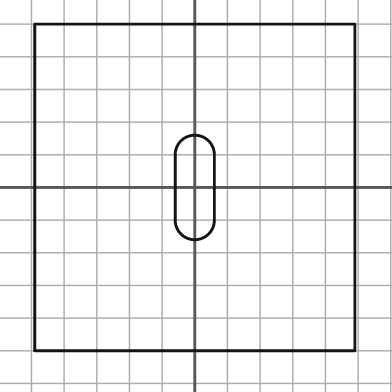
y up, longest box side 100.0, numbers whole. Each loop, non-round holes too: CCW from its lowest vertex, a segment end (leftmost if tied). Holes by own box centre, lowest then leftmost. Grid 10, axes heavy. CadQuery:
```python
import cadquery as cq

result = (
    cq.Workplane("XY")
    .moveTo(-49.0, -50.0)
    .lineTo(49.0, -50.0)
    .lineTo(49.0, 50.0)
    .lineTo(-49.0, 50.0)
    .close()
    .moveTo(-6.0, -10.0)
    .threePointArc((0.0, -16.0), (6.0, -10.0))
    .lineTo(6.0, 10.0)
    .threePointArc((0.0, 16.0), (-6.0, 10.0))
    .close()
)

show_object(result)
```